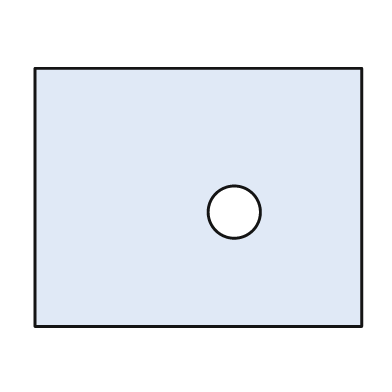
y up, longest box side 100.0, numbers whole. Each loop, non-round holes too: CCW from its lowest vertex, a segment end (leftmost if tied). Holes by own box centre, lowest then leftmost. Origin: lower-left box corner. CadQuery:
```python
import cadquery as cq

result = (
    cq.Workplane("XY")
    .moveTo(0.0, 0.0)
    .lineTo(100.0, 0.0)
    .lineTo(100.0, 79.0)
    .lineTo(0.0, 79.0)
    .close()
    .moveTo(61.0, 35.0)
    .circle(8.0)
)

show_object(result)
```